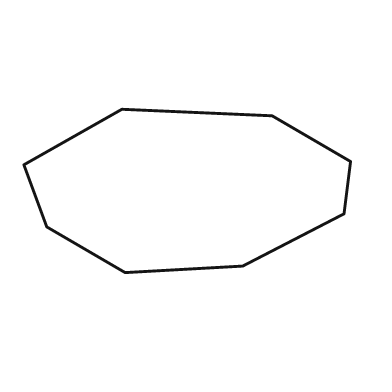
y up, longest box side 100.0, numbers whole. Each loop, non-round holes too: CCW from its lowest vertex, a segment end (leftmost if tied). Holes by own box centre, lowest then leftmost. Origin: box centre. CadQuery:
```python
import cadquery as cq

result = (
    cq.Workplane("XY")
    .moveTo(-19.0, -25.0)
    .lineTo(17.0, -23.0)
    .lineTo(48.0, -7.0)
    .lineTo(50.0, 9.0)
    .lineTo(26.0, 23.0)
    .lineTo(-20.0, 25.0)
    .lineTo(-50.0, 8.0)
    .lineTo(-43.0, -11.0)
    .close()
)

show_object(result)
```